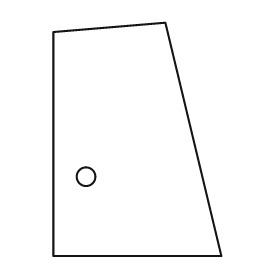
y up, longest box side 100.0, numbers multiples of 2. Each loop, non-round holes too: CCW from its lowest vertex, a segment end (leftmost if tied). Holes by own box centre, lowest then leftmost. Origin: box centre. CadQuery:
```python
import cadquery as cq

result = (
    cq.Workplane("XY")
    .moveTo(-36.0, -50.0)
    .lineTo(36.0, -50.0)
    .lineTo(12.0, 50.0)
    .lineTo(-36.0, 46.0)
    .close()
    .moveTo(-22.0, -16.0)
    .circle(4.0)
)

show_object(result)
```